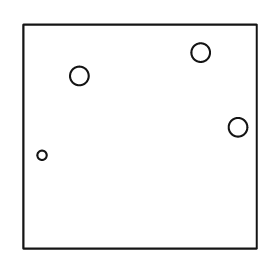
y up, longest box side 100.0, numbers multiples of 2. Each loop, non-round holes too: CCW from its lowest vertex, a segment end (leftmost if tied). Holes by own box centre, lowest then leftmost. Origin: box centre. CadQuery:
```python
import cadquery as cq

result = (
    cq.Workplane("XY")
    .moveTo(-50.0, -48.0)
    .lineTo(50.0, -48.0)
    .lineTo(50.0, 48.0)
    .lineTo(-50.0, 48.0)
    .close()
    .moveTo(-42.0, -8.0)
    .circle(2.0)
    .moveTo(42.0, 4.0)
    .circle(4.0)
    .moveTo(-26.0, 26.0)
    .circle(4.0)
    .moveTo(26.0, 36.0)
    .circle(4.0)
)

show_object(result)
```